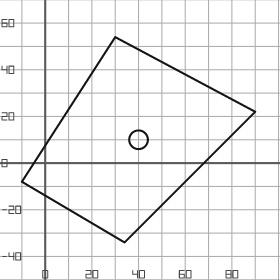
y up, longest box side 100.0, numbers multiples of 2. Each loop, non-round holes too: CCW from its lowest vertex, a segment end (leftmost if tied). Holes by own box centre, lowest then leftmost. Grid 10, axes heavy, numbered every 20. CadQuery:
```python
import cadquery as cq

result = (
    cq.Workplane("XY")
    .moveTo(34.0, -34.0)
    .lineTo(90.0, 22.0)
    .lineTo(30.0, 54.0)
    .lineTo(-10.0, -8.0)
    .close()
    .moveTo(40.0, 10.0)
    .circle(4.0)
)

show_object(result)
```